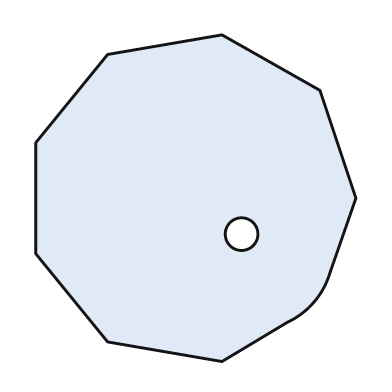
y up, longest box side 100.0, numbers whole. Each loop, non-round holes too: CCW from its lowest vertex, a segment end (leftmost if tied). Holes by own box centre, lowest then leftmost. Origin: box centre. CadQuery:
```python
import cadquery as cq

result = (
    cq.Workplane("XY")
    .moveTo(8.0, -50.0)
    .lineTo(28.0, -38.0)
    .threePointArc((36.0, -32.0), (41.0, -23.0))
    .lineTo(49.0, 0.0)
    .lineTo(38.0, 33.0)
    .lineTo(8.0, 50.0)
    .lineTo(-27.0, 44.0)
    .lineTo(-49.0, 17.0)
    .lineTo(-49.0, -17.0)
    .lineTo(-27.0, -44.0)
    .close()
    .moveTo(14.0, -11.0)
    .circle(5.0)
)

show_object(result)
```